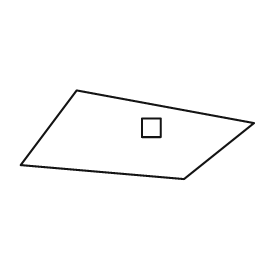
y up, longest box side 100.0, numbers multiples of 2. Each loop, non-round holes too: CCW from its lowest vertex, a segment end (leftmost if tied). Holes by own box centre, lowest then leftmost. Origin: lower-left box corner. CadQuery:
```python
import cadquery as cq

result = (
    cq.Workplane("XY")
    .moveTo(70.0, 0.0)
    .lineTo(100.0, 24.0)
    .lineTo(24.0, 38.0)
    .lineTo(0.0, 6.0)
    .close()
    .moveTo(52.0, 18.0)
    .lineTo(60.0, 18.0)
    .lineTo(60.0, 26.0)
    .lineTo(52.0, 26.0)
    .close()
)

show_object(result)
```